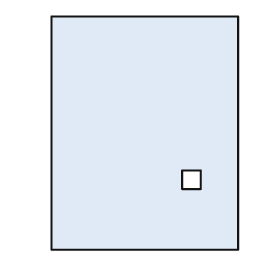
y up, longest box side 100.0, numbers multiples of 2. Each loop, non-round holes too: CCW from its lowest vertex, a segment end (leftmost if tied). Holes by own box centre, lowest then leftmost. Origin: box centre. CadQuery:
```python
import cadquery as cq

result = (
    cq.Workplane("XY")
    .moveTo(-40.0, -50.0)
    .lineTo(40.0, -50.0)
    .lineTo(40.0, 50.0)
    .lineTo(-40.0, 50.0)
    .close()
    .moveTo(16.0, -24.0)
    .lineTo(24.0, -24.0)
    .lineTo(24.0, -16.0)
    .lineTo(16.0, -16.0)
    .close()
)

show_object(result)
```